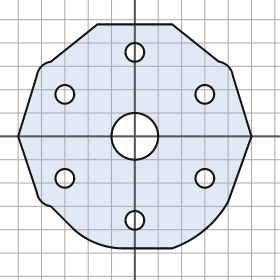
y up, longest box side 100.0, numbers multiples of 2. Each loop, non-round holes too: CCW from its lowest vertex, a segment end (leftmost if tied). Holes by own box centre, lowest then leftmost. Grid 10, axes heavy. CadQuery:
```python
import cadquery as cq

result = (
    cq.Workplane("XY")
    .moveTo(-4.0, -48.0)
    .lineTo(16.0, -48.0)
    .threePointArc((30.0, -40.0), (40.0, -28.0))
    .lineTo(50.0, 0.0)
    .lineTo(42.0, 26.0)
    .threePointArc((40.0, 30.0), (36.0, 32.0))
    .lineTo(16.0, 48.0)
    .lineTo(-16.0, 48.0)
    .lineTo(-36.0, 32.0)
    .threePointArc((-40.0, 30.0), (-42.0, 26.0))
    .lineTo(-50.0, 0.0)
    .lineTo(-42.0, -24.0)
    .threePointArc((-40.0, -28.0), (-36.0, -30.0))
    .lineTo(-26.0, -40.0)
    .threePointArc((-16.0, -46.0), (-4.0, -48.0))
    .close()
    .moveTo(0.0, -36.0)
    .circle(4.0)
    .moveTo(-30.0, -18.0)
    .circle(4.0)
    .moveTo(30.0, -18.0)
    .circle(4.0)
    .moveTo(0.0, 0.0)
    .circle(10.0)
    .moveTo(-30.0, 18.0)
    .circle(4.0)
    .moveTo(30.0, 18.0)
    .circle(4.0)
    .moveTo(0.0, 36.0)
    .circle(4.0)
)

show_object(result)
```